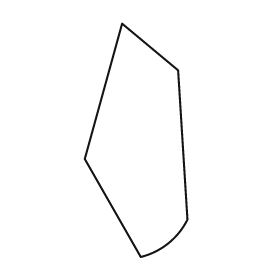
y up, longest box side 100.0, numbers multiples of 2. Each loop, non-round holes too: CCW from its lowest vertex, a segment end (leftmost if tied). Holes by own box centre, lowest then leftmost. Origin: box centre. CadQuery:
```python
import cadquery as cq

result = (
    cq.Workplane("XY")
    .moveTo(2.0, -50.0)
    .threePointArc((14.0, -44.0), (22.0, -34.0))
    .lineTo(18.0, 30.0)
    .lineTo(-6.0, 50.0)
    .lineTo(-22.0, -8.0)
    .close()
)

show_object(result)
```